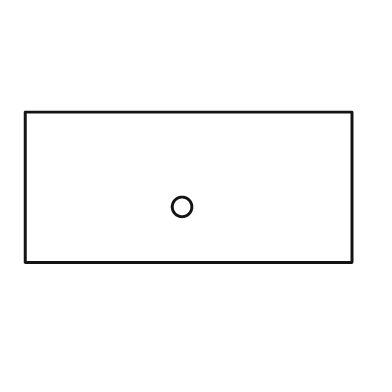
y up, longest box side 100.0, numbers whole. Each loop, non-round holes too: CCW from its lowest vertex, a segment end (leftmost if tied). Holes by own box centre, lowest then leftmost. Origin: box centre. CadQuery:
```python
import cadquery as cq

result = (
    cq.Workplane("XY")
    .moveTo(-50.0, -23.0)
    .lineTo(50.0, -23.0)
    .lineTo(50.0, 23.0)
    .lineTo(-50.0, 23.0)
    .close()
    .moveTo(-2.0, -6.0)
    .circle(3.0)
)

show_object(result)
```